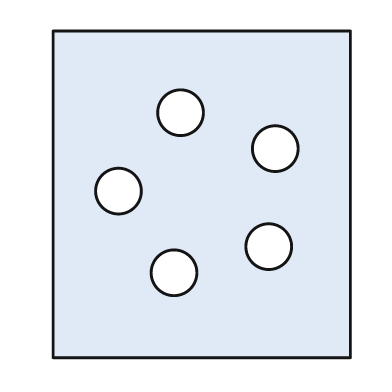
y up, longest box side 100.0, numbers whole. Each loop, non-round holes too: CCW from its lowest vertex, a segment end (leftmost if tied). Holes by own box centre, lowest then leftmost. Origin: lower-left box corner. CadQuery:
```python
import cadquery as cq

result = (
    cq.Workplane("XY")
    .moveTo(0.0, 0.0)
    .lineTo(91.0, 0.0)
    .lineTo(91.0, 100.0)
    .lineTo(0.0, 100.0)
    .close()
    .moveTo(37.0, 26.0)
    .circle(7.0)
    .moveTo(66.0, 34.0)
    .circle(7.0)
    .moveTo(20.0, 51.0)
    .circle(7.0)
    .moveTo(68.0, 64.0)
    .circle(7.0)
    .moveTo(39.0, 75.0)
    .circle(7.0)
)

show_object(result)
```